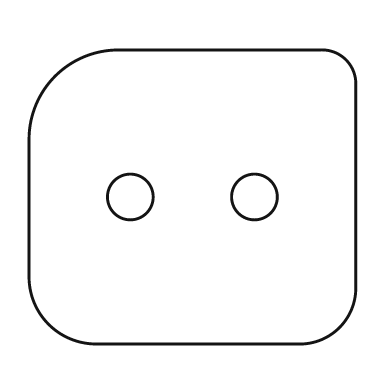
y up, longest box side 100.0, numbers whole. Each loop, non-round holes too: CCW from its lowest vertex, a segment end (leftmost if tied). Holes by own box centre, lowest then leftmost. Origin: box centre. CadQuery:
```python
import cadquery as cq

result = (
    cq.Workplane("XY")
    .moveTo(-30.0, -45.0)
    .lineTo(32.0, -45.0)
    .threePointArc((45.0, -40.0), (50.0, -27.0))
    .lineTo(50.0, 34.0)
    .threePointArc((47.0, 42.0), (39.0, 45.0))
    .lineTo(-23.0, 45.0)
    .threePointArc((-42.0, 37.0), (-50.0, 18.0))
    .lineTo(-50.0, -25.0)
    .threePointArc((-44.0, -39.0), (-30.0, -45.0))
    .close()
    .moveTo(-19.0, 0.0)
    .circle(7.0)
    .moveTo(19.0, 0.0)
    .circle(7.0)
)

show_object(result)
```